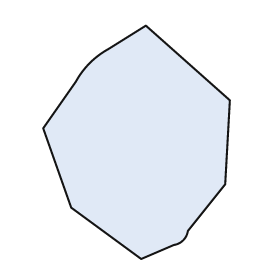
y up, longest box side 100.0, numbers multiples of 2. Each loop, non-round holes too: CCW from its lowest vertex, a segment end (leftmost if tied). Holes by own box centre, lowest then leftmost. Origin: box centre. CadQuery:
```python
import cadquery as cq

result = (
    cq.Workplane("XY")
    .moveTo(2.0, -50.0)
    .lineTo(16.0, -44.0)
    .threePointArc((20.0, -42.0), (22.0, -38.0))
    .lineTo(38.0, -18.0)
    .lineTo(40.0, 18.0)
    .lineTo(4.0, 50.0)
    .lineTo(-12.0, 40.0)
    .threePointArc((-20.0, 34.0), (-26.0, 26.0))
    .lineTo(-40.0, 6.0)
    .lineTo(-28.0, -28.0)
    .close()
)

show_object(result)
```